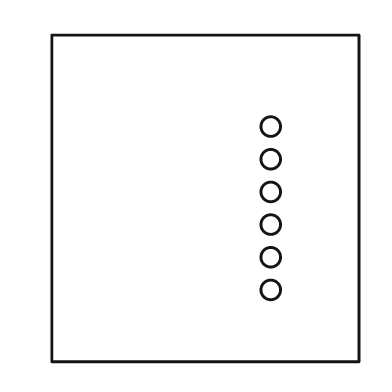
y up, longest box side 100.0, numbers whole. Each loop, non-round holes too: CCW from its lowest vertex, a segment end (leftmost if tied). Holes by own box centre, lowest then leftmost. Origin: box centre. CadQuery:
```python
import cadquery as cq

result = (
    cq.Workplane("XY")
    .moveTo(-47.0, -50.0)
    .lineTo(47.0, -50.0)
    .lineTo(47.0, 50.0)
    .lineTo(-47.0, 50.0)
    .close()
    .moveTo(20.0, -28.0)
    .circle(3.0)
    .moveTo(20.0, -18.0)
    .circle(3.0)
    .moveTo(20.0, -8.0)
    .circle(3.0)
    .moveTo(20.0, 2.0)
    .circle(3.0)
    .moveTo(20.0, 12.0)
    .circle(3.0)
    .moveTo(20.0, 22.0)
    .circle(3.0)
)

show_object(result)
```